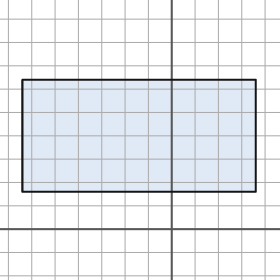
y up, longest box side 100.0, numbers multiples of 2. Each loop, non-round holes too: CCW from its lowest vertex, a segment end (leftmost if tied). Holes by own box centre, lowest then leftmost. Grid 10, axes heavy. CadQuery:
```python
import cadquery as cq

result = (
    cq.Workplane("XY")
    .moveTo(-64.0, 16.0)
    .lineTo(36.0, 16.0)
    .lineTo(36.0, 64.0)
    .lineTo(-64.0, 64.0)
    .close()
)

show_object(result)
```